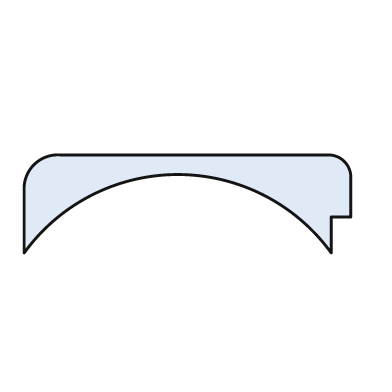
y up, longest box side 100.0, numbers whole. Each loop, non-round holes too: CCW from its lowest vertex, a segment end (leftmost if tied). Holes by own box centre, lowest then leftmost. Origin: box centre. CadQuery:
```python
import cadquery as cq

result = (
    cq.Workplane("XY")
    .moveTo(-50.0, -15.0)
    .threePointArc((-3.0, 9.0), (44.0, -15.0))
    .lineTo(44.0, -4.0)
    .lineTo(50.0, -4.0)
    .lineTo(50.0, 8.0)
    .threePointArc((48.0, 13.0), (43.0, 15.0))
    .lineTo(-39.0, 15.0)
    .threePointArc((-47.0, 12.0), (-50.0, 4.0))
    .close()
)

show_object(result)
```